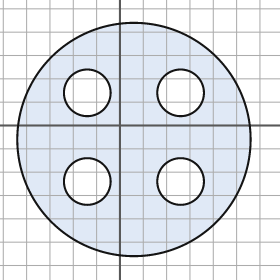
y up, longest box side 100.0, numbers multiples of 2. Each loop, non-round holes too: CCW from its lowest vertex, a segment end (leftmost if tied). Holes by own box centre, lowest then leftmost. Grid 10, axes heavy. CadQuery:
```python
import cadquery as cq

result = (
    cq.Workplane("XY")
    .moveTo(6.0, -6.0)
    .circle(50.0)
    .moveTo(-14.0, -24.0)
    .circle(10.0)
    .moveTo(26.0, -24.0)
    .circle(10.0)
    .moveTo(-14.0, 14.0)
    .circle(10.0)
    .moveTo(26.0, 14.0)
    .circle(10.0)
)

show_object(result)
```